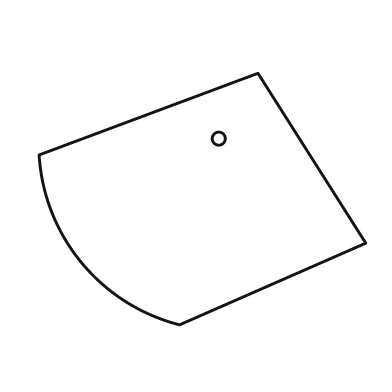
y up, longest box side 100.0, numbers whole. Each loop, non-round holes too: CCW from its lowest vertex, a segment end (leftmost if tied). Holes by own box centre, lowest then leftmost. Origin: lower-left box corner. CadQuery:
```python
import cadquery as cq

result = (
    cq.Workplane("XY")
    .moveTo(43.0, 0.0)
    .lineTo(100.0, 25.0)
    .lineTo(67.0, 77.0)
    .lineTo(0.0, 52.0)
    .threePointArc((13.0, 19.0), (43.0, 0.0))
    .close()
    .moveTo(55.0, 57.0)
    .circle(2.0)
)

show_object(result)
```